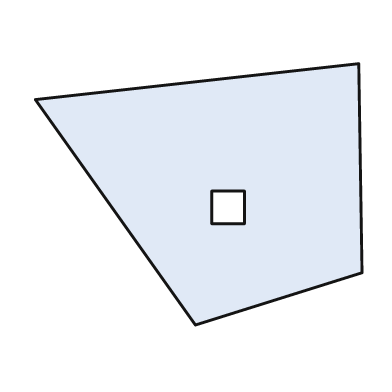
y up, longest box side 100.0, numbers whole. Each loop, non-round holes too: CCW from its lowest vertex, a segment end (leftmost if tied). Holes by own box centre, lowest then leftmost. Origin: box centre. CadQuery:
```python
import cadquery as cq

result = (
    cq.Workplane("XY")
    .moveTo(-1.0, -40.0)
    .lineTo(50.0, -24.0)
    .lineTo(49.0, 40.0)
    .lineTo(-50.0, 29.0)
    .close()
    .moveTo(4.0, -9.0)
    .lineTo(14.0, -9.0)
    .lineTo(14.0, 1.0)
    .lineTo(4.0, 1.0)
    .close()
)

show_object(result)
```